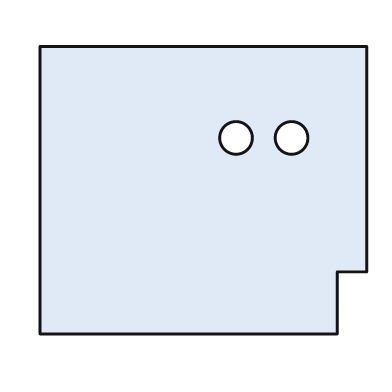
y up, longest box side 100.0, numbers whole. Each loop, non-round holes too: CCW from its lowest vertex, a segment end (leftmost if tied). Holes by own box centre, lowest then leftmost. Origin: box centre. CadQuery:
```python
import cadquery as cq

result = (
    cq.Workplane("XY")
    .moveTo(-50.0, -44.0)
    .lineTo(41.0, -44.0)
    .lineTo(41.0, -25.0)
    .lineTo(50.0, -25.0)
    .lineTo(50.0, 44.0)
    .lineTo(-50.0, 44.0)
    .close()
    .moveTo(10.0, 16.0)
    .circle(5.0)
    .moveTo(27.0, 16.0)
    .circle(5.0)
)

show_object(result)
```